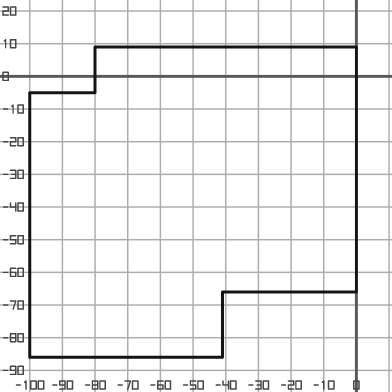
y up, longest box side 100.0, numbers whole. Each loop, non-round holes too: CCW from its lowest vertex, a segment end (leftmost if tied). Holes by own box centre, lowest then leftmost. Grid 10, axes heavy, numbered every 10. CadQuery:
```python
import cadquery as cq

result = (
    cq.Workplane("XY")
    .moveTo(-100.0, -86.0)
    .lineTo(-41.0, -86.0)
    .lineTo(-41.0, -66.0)
    .lineTo(0.0, -66.0)
    .lineTo(0.0, 9.0)
    .lineTo(-80.0, 9.0)
    .lineTo(-80.0, -5.0)
    .lineTo(-100.0, -5.0)
    .close()
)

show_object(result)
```